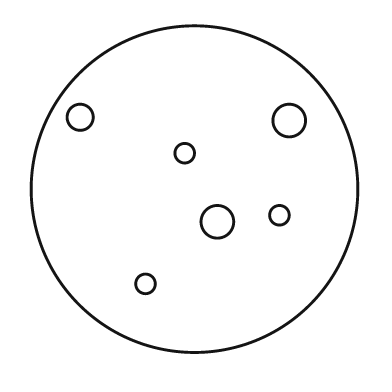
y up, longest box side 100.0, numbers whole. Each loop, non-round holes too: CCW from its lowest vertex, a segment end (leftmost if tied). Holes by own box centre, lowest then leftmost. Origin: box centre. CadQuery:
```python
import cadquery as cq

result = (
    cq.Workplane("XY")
    .moveTo(0.0, 0.0)
    .circle(50.0)
    .moveTo(-15.0, -29.0)
    .circle(3.0)
    .moveTo(7.0, -10.0)
    .circle(5.0)
    .moveTo(26.0, -8.0)
    .circle(3.0)
    .moveTo(-3.0, 11.0)
    .circle(3.0)
    .moveTo(29.0, 21.0)
    .circle(5.0)
    .moveTo(-35.0, 22.0)
    .circle(4.0)
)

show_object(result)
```